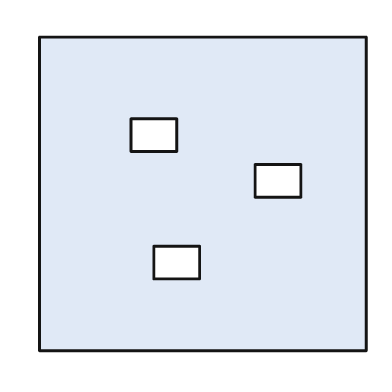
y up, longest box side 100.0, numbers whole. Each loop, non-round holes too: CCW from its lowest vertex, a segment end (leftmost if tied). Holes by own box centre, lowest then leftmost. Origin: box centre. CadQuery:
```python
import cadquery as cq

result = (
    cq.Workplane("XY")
    .moveTo(-50.0, -48.0)
    .lineTo(50.0, -48.0)
    .lineTo(50.0, 48.0)
    .lineTo(-50.0, 48.0)
    .close()
    .moveTo(-15.0, -26.0)
    .lineTo(-1.0, -26.0)
    .lineTo(-1.0, -16.0)
    .lineTo(-15.0, -16.0)
    .close()
    .moveTo(16.0, -1.0)
    .lineTo(30.0, -1.0)
    .lineTo(30.0, 9.0)
    .lineTo(16.0, 9.0)
    .close()
    .moveTo(-22.0, 13.0)
    .lineTo(-8.0, 13.0)
    .lineTo(-8.0, 23.0)
    .lineTo(-22.0, 23.0)
    .close()
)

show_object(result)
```